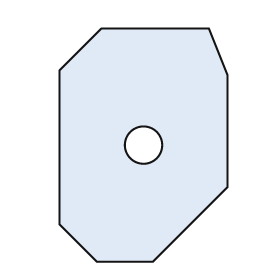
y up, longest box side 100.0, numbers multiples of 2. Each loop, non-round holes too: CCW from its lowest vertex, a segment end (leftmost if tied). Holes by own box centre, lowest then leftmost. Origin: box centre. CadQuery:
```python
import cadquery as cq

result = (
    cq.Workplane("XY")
    .moveTo(-20.0, -50.0)
    .lineTo(4.0, -50.0)
    .lineTo(36.0, -18.0)
    .lineTo(36.0, 30.0)
    .lineTo(28.0, 50.0)
    .lineTo(-18.0, 50.0)
    .lineTo(-36.0, 32.0)
    .lineTo(-36.0, -34.0)
    .close()
    .moveTo(0.0, 0.0)
    .circle(8.0)
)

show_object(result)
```